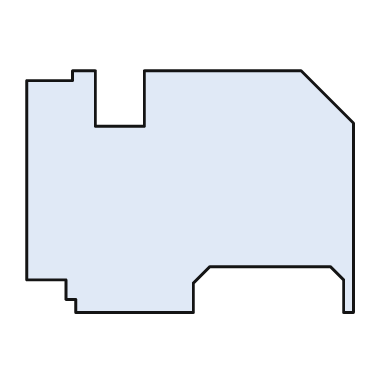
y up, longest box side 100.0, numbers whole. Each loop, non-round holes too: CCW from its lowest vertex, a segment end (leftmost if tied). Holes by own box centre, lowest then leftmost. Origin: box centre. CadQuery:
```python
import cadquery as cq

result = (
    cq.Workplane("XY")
    .moveTo(-35.0, -37.0)
    .lineTo(1.0, -37.0)
    .lineTo(1.0, -28.0)
    .lineTo(6.0, -23.0)
    .lineTo(43.0, -23.0)
    .lineTo(47.0, -27.0)
    .lineTo(47.0, -37.0)
    .lineTo(50.0, -37.0)
    .lineTo(50.0, 21.0)
    .lineTo(34.0, 37.0)
    .lineTo(-14.0, 37.0)
    .lineTo(-14.0, 20.0)
    .lineTo(-29.0, 20.0)
    .lineTo(-29.0, 37.0)
    .lineTo(-36.0, 37.0)
    .lineTo(-36.0, 34.0)
    .lineTo(-50.0, 34.0)
    .lineTo(-50.0, -27.0)
    .lineTo(-38.0, -27.0)
    .lineTo(-38.0, -33.0)
    .lineTo(-35.0, -33.0)
    .close()
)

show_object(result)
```